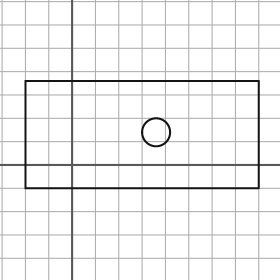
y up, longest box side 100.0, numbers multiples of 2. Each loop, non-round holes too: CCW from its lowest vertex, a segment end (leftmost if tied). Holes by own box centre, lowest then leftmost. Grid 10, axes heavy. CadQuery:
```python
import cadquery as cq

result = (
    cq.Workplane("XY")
    .moveTo(-20.0, -10.0)
    .lineTo(80.0, -10.0)
    .lineTo(80.0, 36.0)
    .lineTo(-20.0, 36.0)
    .close()
    .moveTo(36.0, 14.0)
    .circle(6.0)
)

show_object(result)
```